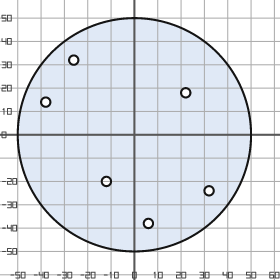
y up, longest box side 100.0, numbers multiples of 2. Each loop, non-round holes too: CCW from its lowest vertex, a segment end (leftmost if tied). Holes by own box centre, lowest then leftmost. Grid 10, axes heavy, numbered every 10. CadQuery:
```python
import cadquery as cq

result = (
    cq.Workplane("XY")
    .moveTo(0.0, 0.0)
    .circle(50.0)
    .moveTo(6.0, -38.0)
    .circle(2.0)
    .moveTo(32.0, -24.0)
    .circle(2.0)
    .moveTo(-12.0, -20.0)
    .circle(2.0)
    .moveTo(-38.0, 14.0)
    .circle(2.0)
    .moveTo(22.0, 18.0)
    .circle(2.0)
    .moveTo(-26.0, 32.0)
    .circle(2.0)
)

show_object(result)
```